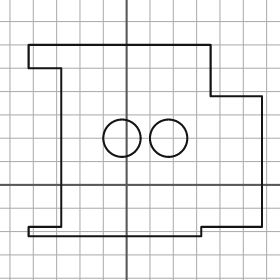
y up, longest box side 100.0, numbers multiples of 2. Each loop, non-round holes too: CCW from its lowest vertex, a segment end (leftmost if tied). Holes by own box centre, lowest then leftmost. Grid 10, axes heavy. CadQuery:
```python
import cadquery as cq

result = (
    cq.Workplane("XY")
    .moveTo(-42.0, -22.0)
    .lineTo(32.0, -22.0)
    .lineTo(32.0, -18.0)
    .lineTo(58.0, -18.0)
    .lineTo(58.0, 38.0)
    .lineTo(36.0, 38.0)
    .lineTo(36.0, 60.0)
    .lineTo(-42.0, 60.0)
    .lineTo(-42.0, 50.0)
    .lineTo(-28.0, 50.0)
    .lineTo(-28.0, -18.0)
    .lineTo(-42.0, -18.0)
    .close()
    .moveTo(-2.0, 20.0)
    .circle(8.0)
    .moveTo(18.0, 20.0)
    .circle(8.0)
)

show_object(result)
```